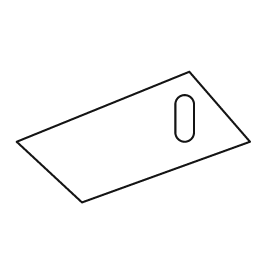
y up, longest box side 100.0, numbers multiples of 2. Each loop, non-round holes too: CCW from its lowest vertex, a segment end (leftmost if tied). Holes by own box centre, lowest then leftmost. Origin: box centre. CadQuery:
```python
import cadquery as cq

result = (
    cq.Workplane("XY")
    .moveTo(-22.0, -28.0)
    .lineTo(50.0, -2.0)
    .lineTo(24.0, 28.0)
    .lineTo(-50.0, -2.0)
    .close()
    .moveTo(18.0, 2.0)
    .threePointArc((22.0, -2.0), (26.0, 2.0))
    .lineTo(26.0, 14.0)
    .threePointArc((22.0, 18.0), (18.0, 14.0))
    .close()
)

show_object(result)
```